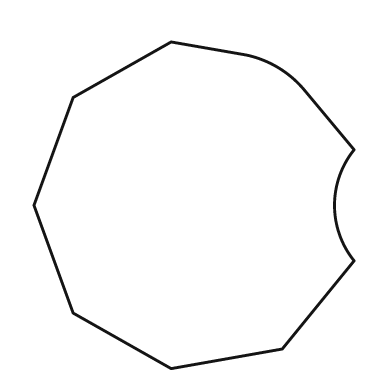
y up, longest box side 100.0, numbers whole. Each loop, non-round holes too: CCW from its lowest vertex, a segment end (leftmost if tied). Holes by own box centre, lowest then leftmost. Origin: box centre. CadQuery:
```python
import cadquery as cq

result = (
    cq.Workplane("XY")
    .moveTo(-7.0, -50.0)
    .lineTo(27.0, -44.0)
    .lineTo(49.0, -17.0)
    .threePointArc((43.0, 0.0), (49.0, 17.0))
    .lineTo(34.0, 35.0)
    .threePointArc((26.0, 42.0), (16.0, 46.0))
    .lineTo(-7.0, 50.0)
    .lineTo(-37.0, 33.0)
    .lineTo(-49.0, 0.0)
    .lineTo(-37.0, -33.0)
    .close()
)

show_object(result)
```